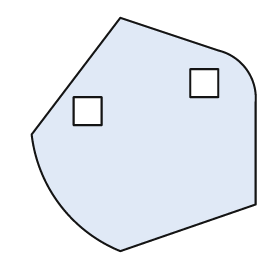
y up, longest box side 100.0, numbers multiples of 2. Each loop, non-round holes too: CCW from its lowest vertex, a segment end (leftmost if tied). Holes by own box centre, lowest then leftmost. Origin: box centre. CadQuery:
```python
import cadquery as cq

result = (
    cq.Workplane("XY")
    .moveTo(-10.0, -50.0)
    .lineTo(48.0, -30.0)
    .lineTo(48.0, 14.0)
    .threePointArc((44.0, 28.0), (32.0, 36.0))
    .lineTo(-10.0, 50.0)
    .lineTo(-48.0, 0.0)
    .threePointArc((-36.0, -30.0), (-10.0, -50.0))
    .close()
    .moveTo(-30.0, 4.0)
    .lineTo(-18.0, 4.0)
    .lineTo(-18.0, 16.0)
    .lineTo(-30.0, 16.0)
    .close()
    .moveTo(20.0, 16.0)
    .lineTo(32.0, 16.0)
    .lineTo(32.0, 28.0)
    .lineTo(20.0, 28.0)
    .close()
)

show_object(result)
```